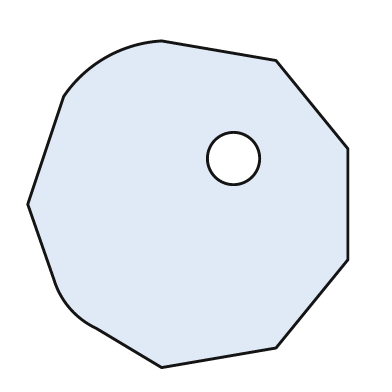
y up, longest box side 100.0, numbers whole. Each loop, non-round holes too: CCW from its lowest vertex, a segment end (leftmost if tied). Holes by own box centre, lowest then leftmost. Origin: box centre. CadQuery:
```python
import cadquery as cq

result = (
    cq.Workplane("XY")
    .moveTo(-8.0, -50.0)
    .lineTo(27.0, -44.0)
    .lineTo(49.0, -17.0)
    .lineTo(49.0, 17.0)
    .lineTo(27.0, 44.0)
    .lineTo(-8.0, 50.0)
    .threePointArc((-25.0, 45.0), (-38.0, 33.0))
    .lineTo(-49.0, 0.0)
    .lineTo(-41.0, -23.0)
    .threePointArc((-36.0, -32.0), (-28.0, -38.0))
    .close()
    .moveTo(14.0, 14.0)
    .circle(8.0)
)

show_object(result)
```